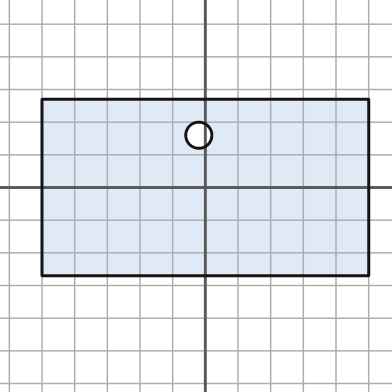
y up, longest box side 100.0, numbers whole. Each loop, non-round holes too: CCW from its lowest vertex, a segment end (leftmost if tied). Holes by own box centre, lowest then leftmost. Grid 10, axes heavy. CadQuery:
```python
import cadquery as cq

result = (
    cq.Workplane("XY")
    .moveTo(-50.0, -27.0)
    .lineTo(50.0, -27.0)
    .lineTo(50.0, 27.0)
    .lineTo(-50.0, 27.0)
    .close()
    .moveTo(-2.0, 16.0)
    .circle(4.0)
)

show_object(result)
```